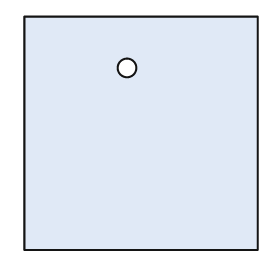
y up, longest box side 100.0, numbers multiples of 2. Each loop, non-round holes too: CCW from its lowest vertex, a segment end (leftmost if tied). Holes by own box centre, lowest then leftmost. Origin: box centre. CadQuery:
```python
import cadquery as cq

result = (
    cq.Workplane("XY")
    .moveTo(-50.0, -50.0)
    .lineTo(50.0, -50.0)
    .lineTo(50.0, 50.0)
    .lineTo(-50.0, 50.0)
    .close()
    .moveTo(-6.0, 28.0)
    .circle(4.0)
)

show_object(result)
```